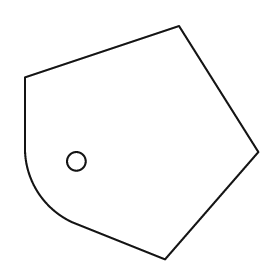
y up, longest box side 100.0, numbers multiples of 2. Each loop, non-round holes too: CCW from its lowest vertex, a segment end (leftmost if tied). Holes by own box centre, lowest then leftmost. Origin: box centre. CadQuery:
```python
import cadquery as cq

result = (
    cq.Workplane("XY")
    .moveTo(10.0, -50.0)
    .lineTo(50.0, -4.0)
    .lineTo(16.0, 50.0)
    .lineTo(-50.0, 28.0)
    .lineTo(-50.0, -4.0)
    .threePointArc((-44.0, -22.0), (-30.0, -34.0))
    .close()
    .moveTo(-28.0, -8.0)
    .circle(4.0)
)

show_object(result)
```